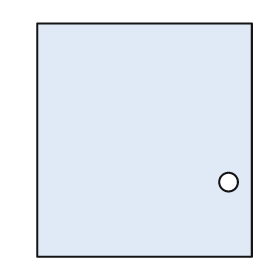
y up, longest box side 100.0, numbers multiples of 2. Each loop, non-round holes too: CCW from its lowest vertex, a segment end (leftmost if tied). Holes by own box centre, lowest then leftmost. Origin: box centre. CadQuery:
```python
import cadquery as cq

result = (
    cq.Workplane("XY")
    .moveTo(-46.0, -50.0)
    .lineTo(46.0, -50.0)
    .lineTo(46.0, 50.0)
    .lineTo(-46.0, 50.0)
    .close()
    .moveTo(36.0, -18.0)
    .circle(4.0)
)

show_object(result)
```